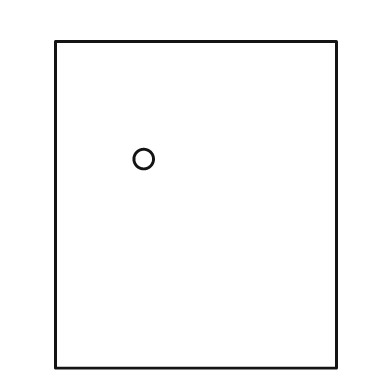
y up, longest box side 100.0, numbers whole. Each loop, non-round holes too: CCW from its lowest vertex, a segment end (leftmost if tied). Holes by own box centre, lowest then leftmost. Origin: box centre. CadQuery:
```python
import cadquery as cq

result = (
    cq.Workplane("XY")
    .moveTo(-43.0, -50.0)
    .lineTo(43.0, -50.0)
    .lineTo(43.0, 50.0)
    .lineTo(-43.0, 50.0)
    .close()
    .moveTo(-16.0, 14.0)
    .circle(3.0)
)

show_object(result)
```